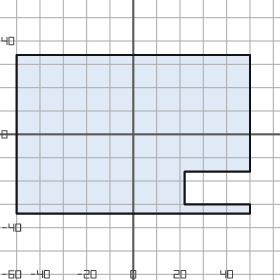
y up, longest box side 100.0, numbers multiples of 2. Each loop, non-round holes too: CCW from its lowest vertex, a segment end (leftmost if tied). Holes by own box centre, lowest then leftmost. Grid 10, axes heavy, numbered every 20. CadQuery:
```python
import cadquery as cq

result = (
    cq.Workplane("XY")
    .moveTo(-50.0, -34.0)
    .lineTo(50.0, -34.0)
    .lineTo(50.0, -30.0)
    .lineTo(22.0, -30.0)
    .lineTo(22.0, -16.0)
    .lineTo(50.0, -16.0)
    .lineTo(50.0, 34.0)
    .lineTo(-50.0, 34.0)
    .close()
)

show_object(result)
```